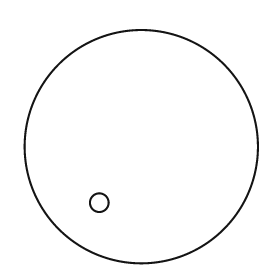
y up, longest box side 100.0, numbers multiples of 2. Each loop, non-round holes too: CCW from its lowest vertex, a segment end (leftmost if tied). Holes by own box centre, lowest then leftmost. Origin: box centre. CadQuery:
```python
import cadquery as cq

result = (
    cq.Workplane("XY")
    .moveTo(0.0, 0.0)
    .circle(50.0)
    .moveTo(-18.0, -24.0)
    .circle(4.0)
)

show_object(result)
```